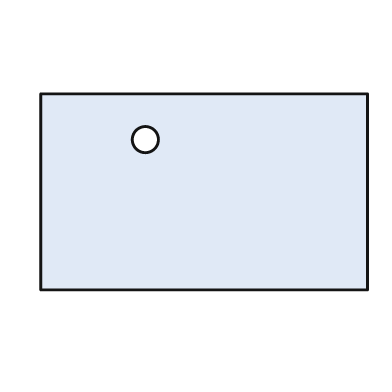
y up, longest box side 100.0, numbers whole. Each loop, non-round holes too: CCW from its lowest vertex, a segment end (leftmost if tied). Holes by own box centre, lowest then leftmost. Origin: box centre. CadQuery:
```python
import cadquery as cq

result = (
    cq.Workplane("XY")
    .moveTo(-50.0, -30.0)
    .lineTo(50.0, -30.0)
    .lineTo(50.0, 30.0)
    .lineTo(-50.0, 30.0)
    .close()
    .moveTo(-18.0, 16.0)
    .circle(4.0)
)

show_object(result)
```